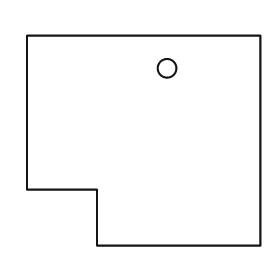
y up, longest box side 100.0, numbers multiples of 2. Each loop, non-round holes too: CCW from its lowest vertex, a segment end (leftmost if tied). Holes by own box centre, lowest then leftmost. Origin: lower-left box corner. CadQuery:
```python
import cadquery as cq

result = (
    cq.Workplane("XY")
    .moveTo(30.0, 0.0)
    .lineTo(100.0, 0.0)
    .lineTo(100.0, 90.0)
    .lineTo(0.0, 90.0)
    .lineTo(0.0, 24.0)
    .lineTo(30.0, 24.0)
    .close()
    .moveTo(60.0, 76.0)
    .circle(4.0)
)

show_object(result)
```